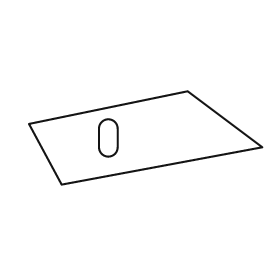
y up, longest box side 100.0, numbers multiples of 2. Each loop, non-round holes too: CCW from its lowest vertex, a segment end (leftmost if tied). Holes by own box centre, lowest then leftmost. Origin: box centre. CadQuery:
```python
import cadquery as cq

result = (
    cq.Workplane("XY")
    .moveTo(-36.0, -20.0)
    .lineTo(50.0, -4.0)
    .lineTo(18.0, 20.0)
    .lineTo(-50.0, 6.0)
    .close()
    .moveTo(-20.0, -4.0)
    .threePointArc((-16.0, -8.0), (-12.0, -4.0))
    .lineTo(-12.0, 4.0)
    .threePointArc((-16.0, 8.0), (-20.0, 4.0))
    .close()
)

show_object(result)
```